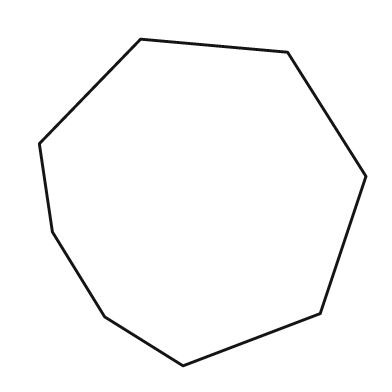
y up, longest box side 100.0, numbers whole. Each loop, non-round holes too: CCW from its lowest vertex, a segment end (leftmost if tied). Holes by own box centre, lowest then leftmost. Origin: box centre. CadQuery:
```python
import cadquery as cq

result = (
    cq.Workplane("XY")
    .moveTo(-6.0, -50.0)
    .lineTo(36.0, -34.0)
    .lineTo(50.0, 8.0)
    .lineTo(26.0, 46.0)
    .lineTo(-19.0, 50.0)
    .lineTo(-50.0, 18.0)
    .lineTo(-46.0, -9.0)
    .lineTo(-30.0, -35.0)
    .close()
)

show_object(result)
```